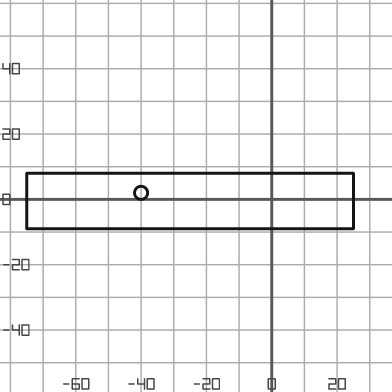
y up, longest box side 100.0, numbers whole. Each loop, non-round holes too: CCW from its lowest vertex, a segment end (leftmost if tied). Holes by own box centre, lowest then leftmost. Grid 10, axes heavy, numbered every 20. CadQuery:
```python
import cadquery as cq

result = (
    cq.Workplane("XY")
    .moveTo(-75.0, -9.0)
    .lineTo(25.0, -9.0)
    .lineTo(25.0, 8.0)
    .lineTo(-75.0, 8.0)
    .close()
    .moveTo(-40.0, 2.0)
    .circle(2.0)
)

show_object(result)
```